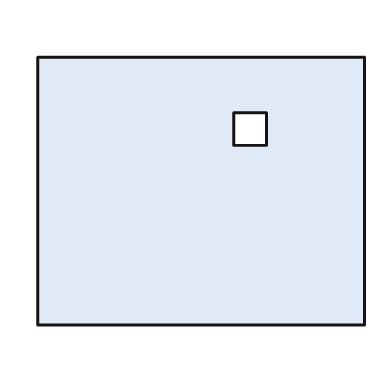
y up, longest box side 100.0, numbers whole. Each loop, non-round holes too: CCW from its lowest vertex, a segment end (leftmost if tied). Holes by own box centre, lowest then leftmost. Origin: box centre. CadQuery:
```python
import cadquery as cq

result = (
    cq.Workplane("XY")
    .moveTo(-50.0, -41.0)
    .lineTo(50.0, -41.0)
    .lineTo(50.0, 41.0)
    .lineTo(-50.0, 41.0)
    .close()
    .moveTo(10.0, 14.0)
    .lineTo(20.0, 14.0)
    .lineTo(20.0, 24.0)
    .lineTo(10.0, 24.0)
    .close()
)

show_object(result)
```